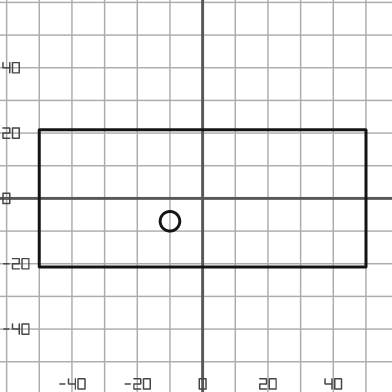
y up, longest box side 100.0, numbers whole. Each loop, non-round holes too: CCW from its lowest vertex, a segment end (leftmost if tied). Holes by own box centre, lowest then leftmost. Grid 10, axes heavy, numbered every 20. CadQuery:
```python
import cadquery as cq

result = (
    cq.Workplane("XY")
    .moveTo(-50.0, -21.0)
    .lineTo(50.0, -21.0)
    .lineTo(50.0, 21.0)
    .lineTo(-50.0, 21.0)
    .close()
    .moveTo(-10.0, -7.0)
    .circle(3.0)
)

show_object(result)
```